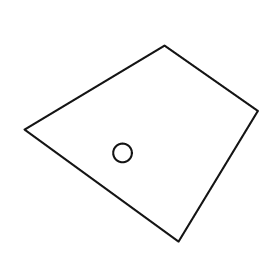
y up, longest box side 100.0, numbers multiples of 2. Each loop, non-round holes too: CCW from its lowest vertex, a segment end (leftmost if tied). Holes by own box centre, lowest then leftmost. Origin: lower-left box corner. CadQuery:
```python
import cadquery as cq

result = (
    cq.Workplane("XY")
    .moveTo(66.0, 0.0)
    .lineTo(100.0, 56.0)
    .lineTo(60.0, 84.0)
    .lineTo(0.0, 48.0)
    .close()
    .moveTo(42.0, 38.0)
    .circle(4.0)
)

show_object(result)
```